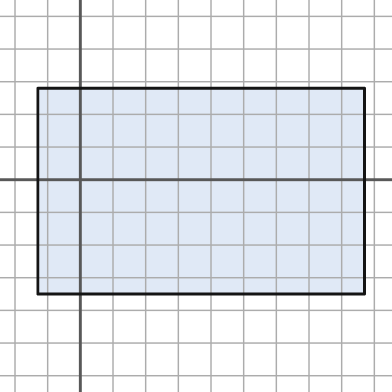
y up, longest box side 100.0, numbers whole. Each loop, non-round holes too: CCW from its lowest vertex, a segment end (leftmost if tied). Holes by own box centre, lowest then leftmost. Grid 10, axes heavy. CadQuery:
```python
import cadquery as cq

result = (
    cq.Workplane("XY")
    .moveTo(-13.0, -35.0)
    .lineTo(87.0, -35.0)
    .lineTo(87.0, 28.0)
    .lineTo(-13.0, 28.0)
    .close()
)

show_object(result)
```